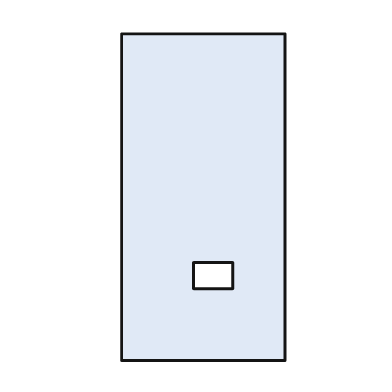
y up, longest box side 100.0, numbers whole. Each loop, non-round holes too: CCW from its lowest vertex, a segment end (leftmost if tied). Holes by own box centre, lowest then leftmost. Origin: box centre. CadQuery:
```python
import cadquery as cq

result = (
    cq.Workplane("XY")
    .moveTo(-25.0, -50.0)
    .lineTo(25.0, -50.0)
    .lineTo(25.0, 50.0)
    .lineTo(-25.0, 50.0)
    .close()
    .moveTo(-3.0, -28.0)
    .lineTo(9.0, -28.0)
    .lineTo(9.0, -20.0)
    .lineTo(-3.0, -20.0)
    .close()
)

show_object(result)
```